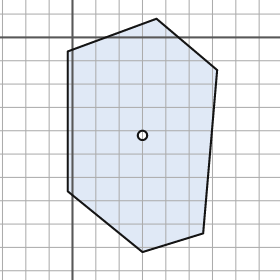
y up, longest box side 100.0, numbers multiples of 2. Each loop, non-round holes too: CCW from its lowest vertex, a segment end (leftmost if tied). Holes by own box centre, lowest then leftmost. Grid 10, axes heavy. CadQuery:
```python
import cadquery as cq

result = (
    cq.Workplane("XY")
    .moveTo(30.0, -92.0)
    .lineTo(56.0, -84.0)
    .lineTo(62.0, -14.0)
    .lineTo(36.0, 8.0)
    .lineTo(-2.0, -6.0)
    .lineTo(-2.0, -66.0)
    .close()
    .moveTo(30.0, -42.0)
    .circle(2.0)
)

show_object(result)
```